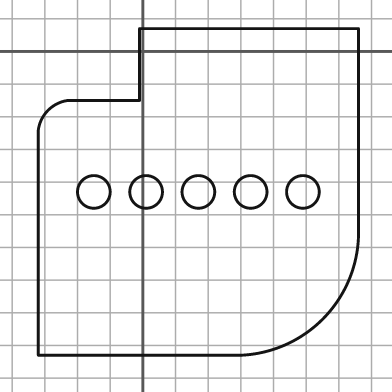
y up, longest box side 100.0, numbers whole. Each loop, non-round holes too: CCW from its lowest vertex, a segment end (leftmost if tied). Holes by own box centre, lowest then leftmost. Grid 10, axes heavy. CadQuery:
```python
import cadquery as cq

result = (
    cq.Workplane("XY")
    .moveTo(-32.0, -93.0)
    .lineTo(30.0, -93.0)
    .threePointArc((55.0, -82.0), (66.0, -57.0))
    .lineTo(66.0, 7.0)
    .lineTo(-1.0, 7.0)
    .lineTo(-1.0, -15.0)
    .lineTo(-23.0, -15.0)
    .threePointArc((-29.0, -18.0), (-32.0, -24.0))
    .close()
    .moveTo(-15.0, -43.0)
    .circle(5.0)
    .moveTo(1.0, -43.0)
    .circle(5.0)
    .moveTo(17.0, -43.0)
    .circle(5.0)
    .moveTo(33.0, -43.0)
    .circle(5.0)
    .moveTo(49.0, -43.0)
    .circle(5.0)
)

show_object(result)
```